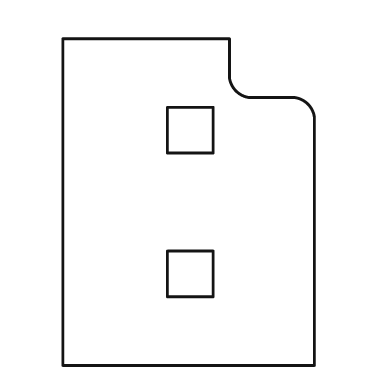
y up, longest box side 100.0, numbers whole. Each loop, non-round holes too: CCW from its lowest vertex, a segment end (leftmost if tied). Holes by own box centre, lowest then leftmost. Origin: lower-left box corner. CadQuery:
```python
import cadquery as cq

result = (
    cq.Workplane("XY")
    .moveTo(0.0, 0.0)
    .lineTo(77.0, 0.0)
    .lineTo(77.0, 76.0)
    .threePointArc((75.0, 80.0), (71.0, 82.0))
    .lineTo(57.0, 82.0)
    .threePointArc((53.0, 84.0), (51.0, 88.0))
    .lineTo(51.0, 100.0)
    .lineTo(0.0, 100.0)
    .close()
    .moveTo(32.0, 21.0)
    .lineTo(46.0, 21.0)
    .lineTo(46.0, 35.0)
    .lineTo(32.0, 35.0)
    .close()
    .moveTo(32.0, 65.0)
    .lineTo(46.0, 65.0)
    .lineTo(46.0, 79.0)
    .lineTo(32.0, 79.0)
    .close()
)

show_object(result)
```